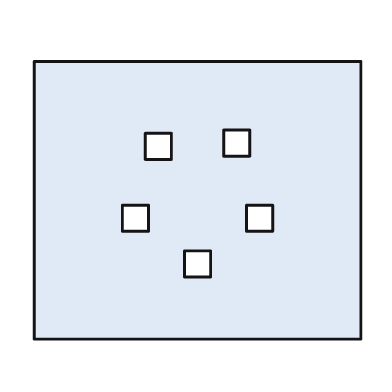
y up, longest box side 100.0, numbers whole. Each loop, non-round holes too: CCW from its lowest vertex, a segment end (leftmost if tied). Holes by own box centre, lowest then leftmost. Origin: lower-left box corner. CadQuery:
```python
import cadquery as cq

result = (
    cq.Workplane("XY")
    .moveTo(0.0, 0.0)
    .lineTo(100.0, 0.0)
    .lineTo(100.0, 85.0)
    .lineTo(0.0, 85.0)
    .close()
    .moveTo(46.0, 19.0)
    .lineTo(54.0, 19.0)
    .lineTo(54.0, 27.0)
    .lineTo(46.0, 27.0)
    .close()
    .moveTo(27.0, 33.0)
    .lineTo(35.0, 33.0)
    .lineTo(35.0, 41.0)
    .lineTo(27.0, 41.0)
    .close()
    .moveTo(65.0, 33.0)
    .lineTo(73.0, 33.0)
    .lineTo(73.0, 41.0)
    .lineTo(65.0, 41.0)
    .close()
    .moveTo(34.0, 55.0)
    .lineTo(42.0, 55.0)
    .lineTo(42.0, 63.0)
    .lineTo(34.0, 63.0)
    .close()
    .moveTo(58.0, 56.0)
    .lineTo(66.0, 56.0)
    .lineTo(66.0, 64.0)
    .lineTo(58.0, 64.0)
    .close()
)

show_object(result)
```